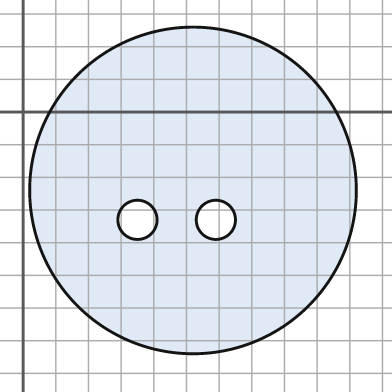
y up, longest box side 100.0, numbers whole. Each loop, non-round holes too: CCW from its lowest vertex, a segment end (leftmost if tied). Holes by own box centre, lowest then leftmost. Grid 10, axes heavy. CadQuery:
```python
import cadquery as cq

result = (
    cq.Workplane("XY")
    .moveTo(52.0, -24.0)
    .circle(50.0)
    .moveTo(35.0, -33.0)
    .circle(6.0)
    .moveTo(59.0, -33.0)
    .circle(6.0)
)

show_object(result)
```